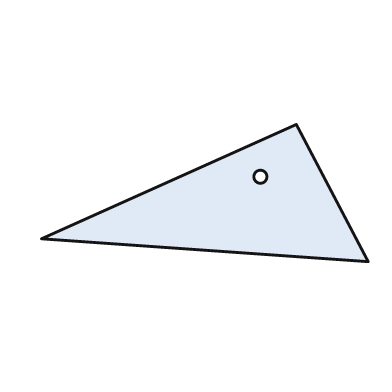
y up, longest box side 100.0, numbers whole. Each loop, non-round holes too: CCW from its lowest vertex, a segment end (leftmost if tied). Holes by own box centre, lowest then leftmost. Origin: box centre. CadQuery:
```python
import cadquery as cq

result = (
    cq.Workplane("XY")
    .moveTo(50.0, -21.0)
    .lineTo(28.0, 21.0)
    .lineTo(-50.0, -14.0)
    .close()
    .moveTo(17.0, 5.0)
    .circle(2.0)
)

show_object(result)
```